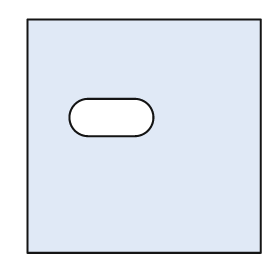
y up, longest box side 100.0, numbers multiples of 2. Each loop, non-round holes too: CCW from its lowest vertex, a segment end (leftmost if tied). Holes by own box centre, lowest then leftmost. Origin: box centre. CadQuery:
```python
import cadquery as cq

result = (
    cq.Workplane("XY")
    .moveTo(-50.0, -50.0)
    .lineTo(50.0, -50.0)
    .lineTo(50.0, 50.0)
    .lineTo(-50.0, 50.0)
    .close()
    .moveTo(-24.0, 0.0)
    .lineTo(-4.0, 0.0)
    .threePointArc((4.0, 8.0), (-4.0, 16.0))
    .lineTo(-24.0, 16.0)
    .threePointArc((-32.0, 8.0), (-24.0, 0.0))
    .close()
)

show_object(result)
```